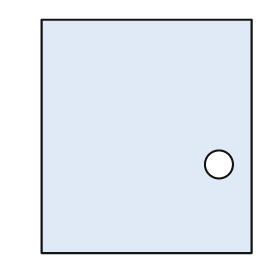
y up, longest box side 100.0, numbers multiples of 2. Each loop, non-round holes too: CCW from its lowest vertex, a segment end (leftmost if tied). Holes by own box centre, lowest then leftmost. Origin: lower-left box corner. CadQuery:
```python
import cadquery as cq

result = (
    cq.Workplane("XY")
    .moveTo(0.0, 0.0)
    .lineTo(90.0, 0.0)
    .lineTo(90.0, 100.0)
    .lineTo(0.0, 100.0)
    .close()
    .moveTo(76.0, 38.0)
    .circle(6.0)
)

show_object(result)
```